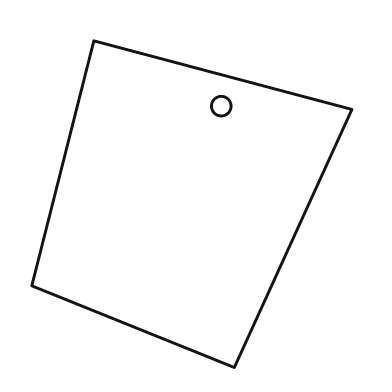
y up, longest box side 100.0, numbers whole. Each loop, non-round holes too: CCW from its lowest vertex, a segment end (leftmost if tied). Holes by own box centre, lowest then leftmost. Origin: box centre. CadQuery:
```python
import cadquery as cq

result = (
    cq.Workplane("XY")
    .moveTo(13.0, -50.0)
    .lineTo(49.0, 29.0)
    .lineTo(-30.0, 50.0)
    .lineTo(-49.0, -25.0)
    .close()
    .moveTo(9.0, 30.0)
    .circle(3.0)
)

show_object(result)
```